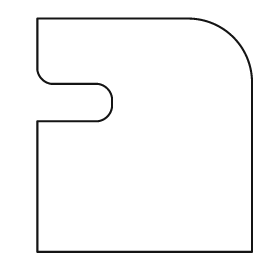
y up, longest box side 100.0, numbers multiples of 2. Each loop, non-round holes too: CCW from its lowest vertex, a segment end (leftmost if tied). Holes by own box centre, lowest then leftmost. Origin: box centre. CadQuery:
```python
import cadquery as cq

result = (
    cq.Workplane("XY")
    .moveTo(-46.0, -50.0)
    .lineTo(46.0, -50.0)
    .lineTo(46.0, 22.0)
    .threePointArc((38.0, 42.0), (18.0, 50.0))
    .lineTo(-46.0, 50.0)
    .lineTo(-46.0, 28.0)
    .threePointArc((-44.0, 24.0), (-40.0, 22.0))
    .lineTo(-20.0, 22.0)
    .threePointArc((-16.0, 20.0), (-14.0, 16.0))
    .lineTo(-14.0, 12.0)
    .threePointArc((-16.0, 8.0), (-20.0, 6.0))
    .lineTo(-46.0, 6.0)
    .close()
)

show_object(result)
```